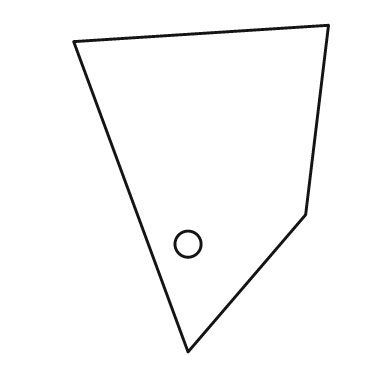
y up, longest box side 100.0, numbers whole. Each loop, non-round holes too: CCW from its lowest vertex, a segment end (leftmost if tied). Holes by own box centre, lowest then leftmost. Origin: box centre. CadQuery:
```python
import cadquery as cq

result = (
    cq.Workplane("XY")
    .moveTo(-4.0, -50.0)
    .lineTo(32.0, -8.0)
    .lineTo(39.0, 50.0)
    .lineTo(-39.0, 45.0)
    .close()
    .moveTo(-4.0, -17.0)
    .circle(4.0)
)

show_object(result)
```